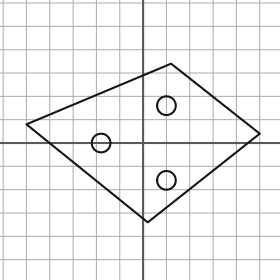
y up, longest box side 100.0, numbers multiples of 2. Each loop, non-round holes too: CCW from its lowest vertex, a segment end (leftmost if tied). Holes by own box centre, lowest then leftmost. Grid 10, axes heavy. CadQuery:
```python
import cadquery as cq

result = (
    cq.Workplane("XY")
    .moveTo(2.0, -34.0)
    .lineTo(50.0, 4.0)
    .lineTo(12.0, 34.0)
    .lineTo(-50.0, 8.0)
    .close()
    .moveTo(10.0, -16.0)
    .circle(4.0)
    .moveTo(-18.0, 0.0)
    .circle(4.0)
    .moveTo(10.0, 16.0)
    .circle(4.0)
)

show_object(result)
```